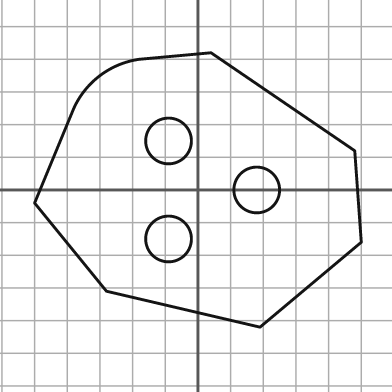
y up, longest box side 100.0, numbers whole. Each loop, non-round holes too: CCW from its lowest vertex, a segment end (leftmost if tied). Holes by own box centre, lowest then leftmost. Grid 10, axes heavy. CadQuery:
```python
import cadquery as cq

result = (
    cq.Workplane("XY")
    .moveTo(19.0, -42.0)
    .lineTo(50.0, -16.0)
    .lineTo(48.0, 12.0)
    .lineTo(4.0, 42.0)
    .lineTo(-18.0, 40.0)
    .threePointArc((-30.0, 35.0), (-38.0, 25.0))
    .lineTo(-50.0, -4.0)
    .lineTo(-28.0, -31.0)
    .close()
    .moveTo(-9.0, -15.0)
    .circle(7.0)
    .moveTo(18.0, 0.0)
    .circle(7.0)
    .moveTo(-9.0, 15.0)
    .circle(7.0)
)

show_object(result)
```